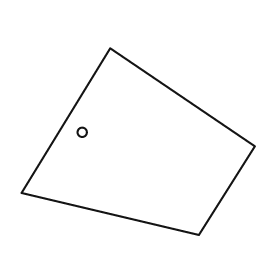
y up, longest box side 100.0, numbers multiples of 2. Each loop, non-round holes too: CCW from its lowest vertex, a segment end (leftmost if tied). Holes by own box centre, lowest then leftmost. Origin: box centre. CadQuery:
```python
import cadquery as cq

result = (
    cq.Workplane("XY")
    .moveTo(26.0, -40.0)
    .lineTo(50.0, -2.0)
    .lineTo(-12.0, 40.0)
    .lineTo(-50.0, -22.0)
    .close()
    .moveTo(-24.0, 4.0)
    .circle(2.0)
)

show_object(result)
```